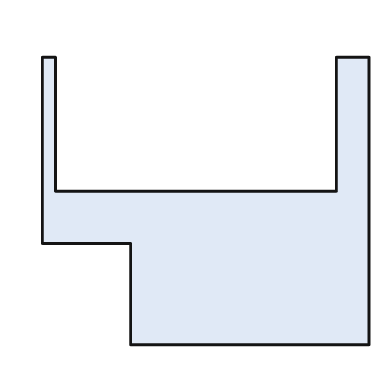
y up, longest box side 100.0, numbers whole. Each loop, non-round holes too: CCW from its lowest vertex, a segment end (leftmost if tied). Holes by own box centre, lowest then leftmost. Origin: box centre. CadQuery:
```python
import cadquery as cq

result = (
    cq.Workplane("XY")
    .moveTo(-23.0, -44.0)
    .lineTo(50.0, -44.0)
    .lineTo(50.0, 44.0)
    .lineTo(40.0, 44.0)
    .lineTo(40.0, 3.0)
    .lineTo(-46.0, 3.0)
    .lineTo(-46.0, 44.0)
    .lineTo(-50.0, 44.0)
    .lineTo(-50.0, -13.0)
    .lineTo(-23.0, -13.0)
    .close()
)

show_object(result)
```